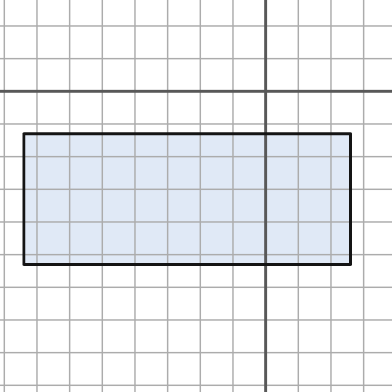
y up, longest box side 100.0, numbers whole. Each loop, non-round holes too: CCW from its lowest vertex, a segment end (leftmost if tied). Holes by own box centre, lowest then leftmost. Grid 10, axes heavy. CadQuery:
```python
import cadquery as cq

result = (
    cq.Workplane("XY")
    .moveTo(-74.0, -53.0)
    .lineTo(26.0, -53.0)
    .lineTo(26.0, -13.0)
    .lineTo(-74.0, -13.0)
    .close()
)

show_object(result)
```